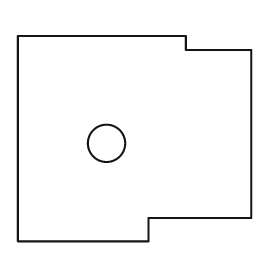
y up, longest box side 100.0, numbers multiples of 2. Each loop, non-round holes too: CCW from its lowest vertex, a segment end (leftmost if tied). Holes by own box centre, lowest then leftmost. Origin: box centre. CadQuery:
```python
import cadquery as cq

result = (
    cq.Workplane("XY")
    .moveTo(-50.0, -44.0)
    .lineTo(6.0, -44.0)
    .lineTo(6.0, -34.0)
    .lineTo(50.0, -34.0)
    .lineTo(50.0, 38.0)
    .lineTo(22.0, 38.0)
    .lineTo(22.0, 44.0)
    .lineTo(-50.0, 44.0)
    .close()
    .moveTo(-12.0, -2.0)
    .circle(8.0)
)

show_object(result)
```